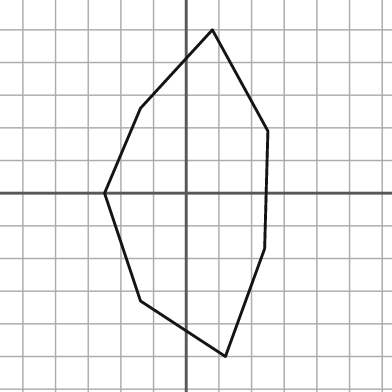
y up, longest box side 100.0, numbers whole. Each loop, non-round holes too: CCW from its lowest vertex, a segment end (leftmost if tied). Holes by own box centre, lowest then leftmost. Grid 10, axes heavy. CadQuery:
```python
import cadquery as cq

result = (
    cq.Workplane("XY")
    .moveTo(12.0, -50.0)
    .lineTo(24.0, -17.0)
    .lineTo(25.0, 19.0)
    .lineTo(8.0, 50.0)
    .lineTo(-14.0, 26.0)
    .lineTo(-25.0, 0.0)
    .lineTo(-14.0, -33.0)
    .close()
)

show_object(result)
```